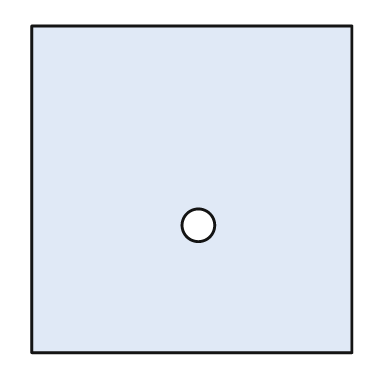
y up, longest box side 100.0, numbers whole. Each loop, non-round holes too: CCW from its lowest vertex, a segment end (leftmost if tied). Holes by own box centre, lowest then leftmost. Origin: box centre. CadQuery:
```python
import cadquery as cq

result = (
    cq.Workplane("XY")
    .moveTo(-49.0, -50.0)
    .lineTo(49.0, -50.0)
    .lineTo(49.0, 50.0)
    .lineTo(-49.0, 50.0)
    .close()
    .moveTo(2.0, -11.0)
    .circle(5.0)
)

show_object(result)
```